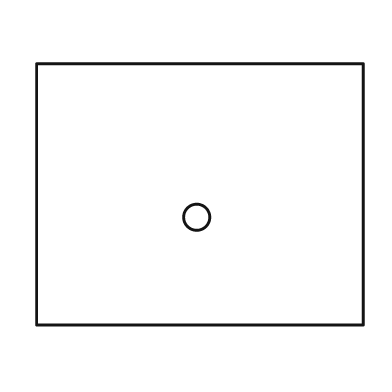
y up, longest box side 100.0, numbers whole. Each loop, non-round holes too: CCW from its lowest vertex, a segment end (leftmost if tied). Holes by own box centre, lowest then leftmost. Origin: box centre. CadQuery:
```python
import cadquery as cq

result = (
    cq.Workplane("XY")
    .moveTo(-50.0, -40.0)
    .lineTo(50.0, -40.0)
    .lineTo(50.0, 40.0)
    .lineTo(-50.0, 40.0)
    .close()
    .moveTo(-1.0, -7.0)
    .circle(4.0)
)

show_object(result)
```